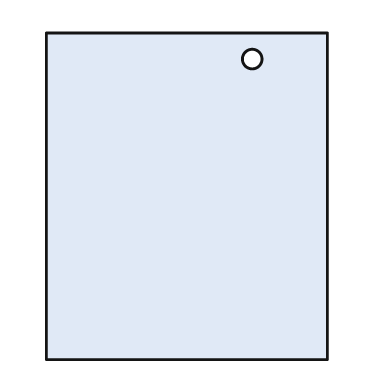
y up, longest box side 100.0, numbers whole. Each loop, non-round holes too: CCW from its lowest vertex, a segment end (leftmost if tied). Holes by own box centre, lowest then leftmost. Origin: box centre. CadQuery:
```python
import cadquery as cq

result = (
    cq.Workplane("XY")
    .moveTo(-43.0, -50.0)
    .lineTo(43.0, -50.0)
    .lineTo(43.0, 50.0)
    .lineTo(-43.0, 50.0)
    .close()
    .moveTo(20.0, 42.0)
    .circle(3.0)
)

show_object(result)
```